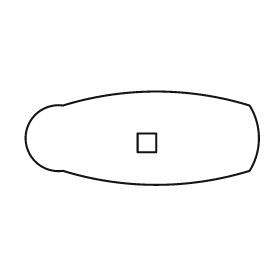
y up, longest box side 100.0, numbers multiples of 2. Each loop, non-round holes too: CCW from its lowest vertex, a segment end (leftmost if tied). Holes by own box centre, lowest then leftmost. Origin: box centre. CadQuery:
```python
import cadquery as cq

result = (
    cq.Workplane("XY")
    .moveTo(-34.0, -14.0)
    .threePointArc((6.0, -20.0), (46.0, -14.0))
    .threePointArc((50.0, 0.0), (46.0, 14.0))
    .threePointArc((6.0, 20.0), (-34.0, 14.0))
    .threePointArc((-50.0, 0.0), (-34.0, -14.0))
    .close()
    .moveTo(-2.0, -6.0)
    .lineTo(6.0, -6.0)
    .lineTo(6.0, 2.0)
    .lineTo(-2.0, 2.0)
    .close()
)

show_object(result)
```